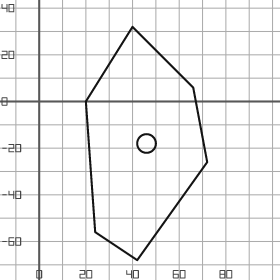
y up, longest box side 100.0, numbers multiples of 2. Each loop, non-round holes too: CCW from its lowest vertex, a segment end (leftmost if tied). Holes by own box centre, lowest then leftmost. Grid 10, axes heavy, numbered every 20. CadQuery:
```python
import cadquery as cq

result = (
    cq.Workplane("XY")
    .moveTo(42.0, -68.0)
    .lineTo(72.0, -26.0)
    .lineTo(66.0, 6.0)
    .lineTo(40.0, 32.0)
    .lineTo(20.0, 0.0)
    .lineTo(24.0, -56.0)
    .close()
    .moveTo(46.0, -18.0)
    .circle(4.0)
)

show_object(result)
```